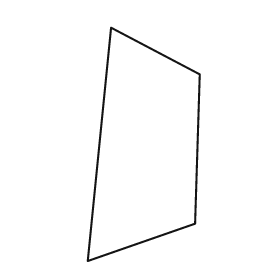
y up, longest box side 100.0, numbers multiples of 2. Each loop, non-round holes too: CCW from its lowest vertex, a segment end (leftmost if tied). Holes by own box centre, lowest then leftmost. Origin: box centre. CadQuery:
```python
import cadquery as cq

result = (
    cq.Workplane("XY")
    .moveTo(-24.0, -50.0)
    .lineTo(22.0, -34.0)
    .lineTo(24.0, 30.0)
    .lineTo(-14.0, 50.0)
    .close()
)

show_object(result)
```